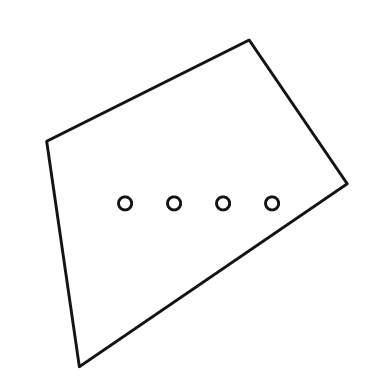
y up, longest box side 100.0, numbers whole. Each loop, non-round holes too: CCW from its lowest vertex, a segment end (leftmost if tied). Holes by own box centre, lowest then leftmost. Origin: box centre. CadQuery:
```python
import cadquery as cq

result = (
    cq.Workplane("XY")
    .moveTo(-36.0, -50.0)
    .lineTo(46.0, 6.0)
    .lineTo(16.0, 50.0)
    .lineTo(-46.0, 19.0)
    .close()
    .moveTo(-22.0, 0.0)
    .circle(2.0)
    .moveTo(-7.0, 0.0)
    .circle(2.0)
    .moveTo(8.0, 0.0)
    .circle(2.0)
    .moveTo(23.0, 0.0)
    .circle(2.0)
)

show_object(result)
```